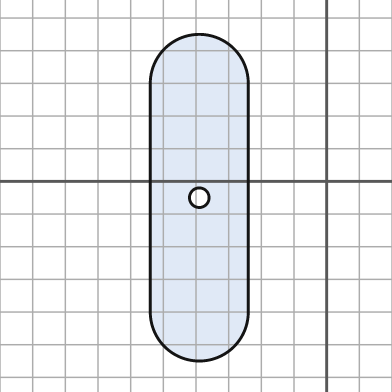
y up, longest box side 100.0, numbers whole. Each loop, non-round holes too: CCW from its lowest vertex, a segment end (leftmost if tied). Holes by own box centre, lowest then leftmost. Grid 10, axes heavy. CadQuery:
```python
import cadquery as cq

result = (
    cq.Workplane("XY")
    .moveTo(-54.0, -40.0)
    .threePointArc((-39.0, -55.0), (-24.0, -40.0))
    .lineTo(-24.0, 30.0)
    .threePointArc((-39.0, 45.0), (-54.0, 30.0))
    .close()
    .moveTo(-39.0, -5.0)
    .circle(3.0)
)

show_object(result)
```